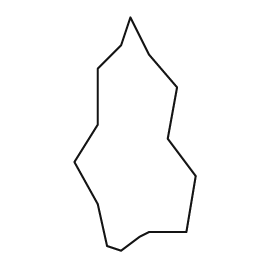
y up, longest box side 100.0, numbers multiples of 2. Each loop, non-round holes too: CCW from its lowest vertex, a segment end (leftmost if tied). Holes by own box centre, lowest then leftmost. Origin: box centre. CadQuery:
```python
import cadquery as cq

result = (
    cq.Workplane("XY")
    .moveTo(-6.0, -50.0)
    .lineTo(2.0, -44.0)
    .lineTo(6.0, -42.0)
    .lineTo(22.0, -42.0)
    .lineTo(26.0, -18.0)
    .lineTo(14.0, -2.0)
    .lineTo(18.0, 20.0)
    .lineTo(6.0, 34.0)
    .lineTo(-2.0, 50.0)
    .lineTo(-6.0, 38.0)
    .lineTo(-16.0, 28.0)
    .lineTo(-16.0, 4.0)
    .lineTo(-26.0, -12.0)
    .lineTo(-16.0, -30.0)
    .lineTo(-12.0, -48.0)
    .close()
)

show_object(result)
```